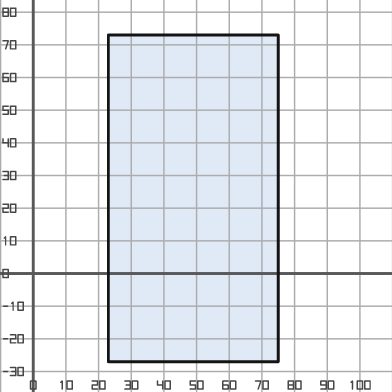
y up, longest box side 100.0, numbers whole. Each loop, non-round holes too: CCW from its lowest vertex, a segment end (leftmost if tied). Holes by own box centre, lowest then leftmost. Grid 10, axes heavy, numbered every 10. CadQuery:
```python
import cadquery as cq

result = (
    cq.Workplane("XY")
    .moveTo(23.0, -27.0)
    .lineTo(75.0, -27.0)
    .lineTo(75.0, 73.0)
    .lineTo(23.0, 73.0)
    .close()
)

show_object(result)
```